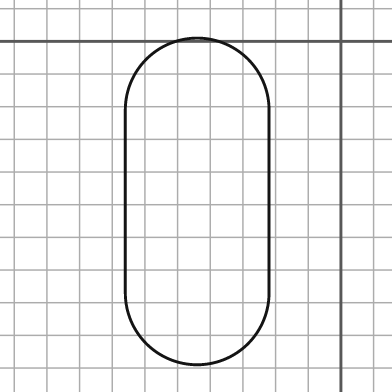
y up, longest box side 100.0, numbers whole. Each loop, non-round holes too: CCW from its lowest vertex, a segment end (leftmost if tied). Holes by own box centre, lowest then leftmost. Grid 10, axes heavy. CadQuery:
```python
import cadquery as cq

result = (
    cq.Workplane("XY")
    .moveTo(-66.0, -77.0)
    .threePointArc((-44.0, -99.0), (-22.0, -77.0))
    .lineTo(-22.0, -21.0)
    .threePointArc((-44.0, 1.0), (-66.0, -21.0))
    .close()
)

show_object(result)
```